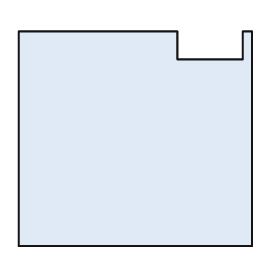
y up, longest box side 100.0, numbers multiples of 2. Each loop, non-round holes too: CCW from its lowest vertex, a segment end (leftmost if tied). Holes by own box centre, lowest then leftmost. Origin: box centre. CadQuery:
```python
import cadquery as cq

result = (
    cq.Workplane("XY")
    .moveTo(-50.0, -46.0)
    .lineTo(50.0, -46.0)
    .lineTo(50.0, 46.0)
    .lineTo(46.0, 46.0)
    .lineTo(46.0, 34.0)
    .lineTo(18.0, 34.0)
    .lineTo(18.0, 46.0)
    .lineTo(-50.0, 46.0)
    .close()
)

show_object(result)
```